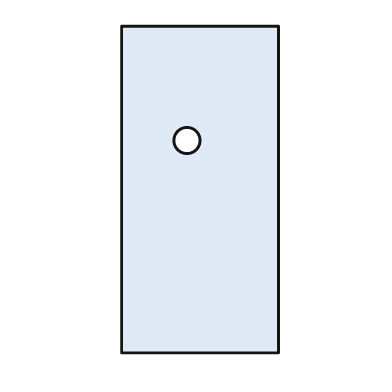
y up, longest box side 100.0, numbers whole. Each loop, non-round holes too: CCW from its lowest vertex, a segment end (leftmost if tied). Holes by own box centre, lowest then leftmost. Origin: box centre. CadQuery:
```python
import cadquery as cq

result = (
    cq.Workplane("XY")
    .moveTo(-24.0, -50.0)
    .lineTo(24.0, -50.0)
    .lineTo(24.0, 50.0)
    .lineTo(-24.0, 50.0)
    .close()
    .moveTo(-4.0, 15.0)
    .circle(4.0)
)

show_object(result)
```